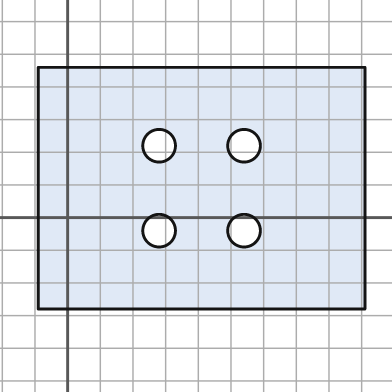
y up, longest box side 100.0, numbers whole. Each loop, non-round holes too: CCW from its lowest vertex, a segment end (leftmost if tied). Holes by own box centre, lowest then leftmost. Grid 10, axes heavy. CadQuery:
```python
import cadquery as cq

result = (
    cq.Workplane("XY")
    .moveTo(-9.0, -28.0)
    .lineTo(91.0, -28.0)
    .lineTo(91.0, 46.0)
    .lineTo(-9.0, 46.0)
    .close()
    .moveTo(28.0, -4.0)
    .circle(5.0)
    .moveTo(54.0, -4.0)
    .circle(5.0)
    .moveTo(28.0, 22.0)
    .circle(5.0)
    .moveTo(54.0, 22.0)
    .circle(5.0)
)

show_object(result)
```